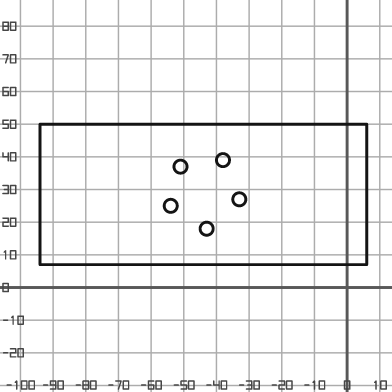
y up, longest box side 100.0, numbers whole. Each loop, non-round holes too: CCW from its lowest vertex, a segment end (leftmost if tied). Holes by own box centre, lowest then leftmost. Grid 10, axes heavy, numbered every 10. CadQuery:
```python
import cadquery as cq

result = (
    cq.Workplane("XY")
    .moveTo(-94.0, 7.0)
    .lineTo(6.0, 7.0)
    .lineTo(6.0, 50.0)
    .lineTo(-94.0, 50.0)
    .close()
    .moveTo(-43.0, 18.0)
    .circle(2.0)
    .moveTo(-54.0, 25.0)
    .circle(2.0)
    .moveTo(-33.0, 27.0)
    .circle(2.0)
    .moveTo(-51.0, 37.0)
    .circle(2.0)
    .moveTo(-38.0, 39.0)
    .circle(2.0)
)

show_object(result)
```